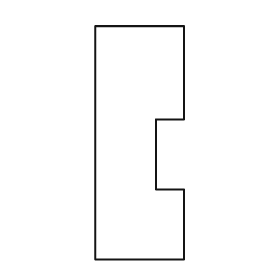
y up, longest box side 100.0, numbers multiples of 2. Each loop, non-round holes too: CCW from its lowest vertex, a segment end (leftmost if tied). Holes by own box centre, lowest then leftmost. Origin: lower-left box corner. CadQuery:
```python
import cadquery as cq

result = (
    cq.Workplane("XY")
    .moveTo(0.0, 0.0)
    .lineTo(38.0, 0.0)
    .lineTo(38.0, 30.0)
    .lineTo(26.0, 30.0)
    .lineTo(26.0, 60.0)
    .lineTo(38.0, 60.0)
    .lineTo(38.0, 100.0)
    .lineTo(0.0, 100.0)
    .close()
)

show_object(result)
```